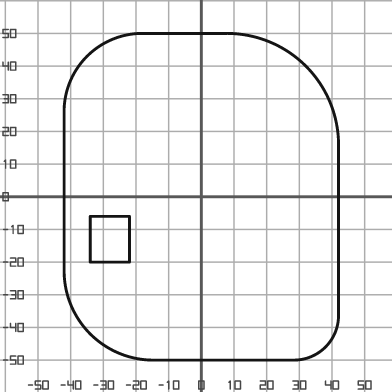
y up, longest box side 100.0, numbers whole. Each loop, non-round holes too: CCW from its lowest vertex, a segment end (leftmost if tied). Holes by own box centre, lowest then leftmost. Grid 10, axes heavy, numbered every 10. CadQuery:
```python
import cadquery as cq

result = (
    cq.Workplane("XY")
    .moveTo(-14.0, -50.0)
    .lineTo(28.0, -50.0)
    .threePointArc((38.0, -46.0), (42.0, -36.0))
    .lineTo(42.0, 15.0)
    .threePointArc((32.0, 40.0), (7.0, 50.0))
    .lineTo(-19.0, 50.0)
    .threePointArc((-35.0, 43.0), (-42.0, 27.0))
    .lineTo(-42.0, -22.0)
    .threePointArc((-34.0, -42.0), (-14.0, -50.0))
    .close()
    .moveTo(-34.0, -20.0)
    .lineTo(-22.0, -20.0)
    .lineTo(-22.0, -6.0)
    .lineTo(-34.0, -6.0)
    .close()
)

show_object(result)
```